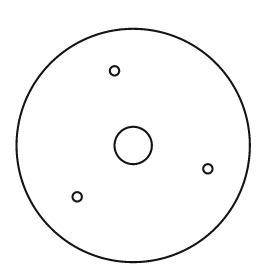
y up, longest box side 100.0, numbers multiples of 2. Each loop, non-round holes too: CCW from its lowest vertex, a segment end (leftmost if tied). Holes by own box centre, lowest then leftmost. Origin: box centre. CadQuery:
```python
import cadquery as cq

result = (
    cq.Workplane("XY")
    .moveTo(0.0, 0.0)
    .circle(50.0)
    .moveTo(-24.0, -22.0)
    .circle(2.0)
    .moveTo(32.0, -10.0)
    .circle(2.0)
    .moveTo(0.0, 0.0)
    .circle(8.0)
    .moveTo(-8.0, 32.0)
    .circle(2.0)
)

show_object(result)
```